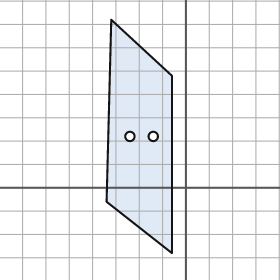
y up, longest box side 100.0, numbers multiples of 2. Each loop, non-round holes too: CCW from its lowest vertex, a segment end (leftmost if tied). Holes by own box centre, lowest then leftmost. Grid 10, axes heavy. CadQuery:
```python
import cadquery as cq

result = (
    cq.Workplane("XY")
    .moveTo(-6.0, -28.0)
    .lineTo(-6.0, 48.0)
    .lineTo(-32.0, 72.0)
    .lineTo(-34.0, -6.0)
    .close()
    .moveTo(-24.0, 22.0)
    .circle(2.0)
    .moveTo(-14.0, 22.0)
    .circle(2.0)
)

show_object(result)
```